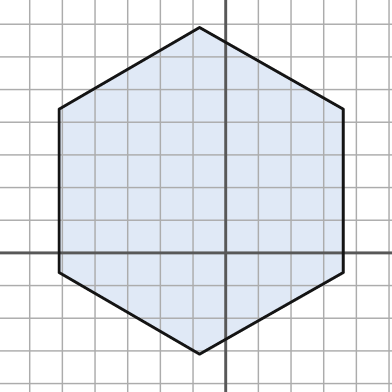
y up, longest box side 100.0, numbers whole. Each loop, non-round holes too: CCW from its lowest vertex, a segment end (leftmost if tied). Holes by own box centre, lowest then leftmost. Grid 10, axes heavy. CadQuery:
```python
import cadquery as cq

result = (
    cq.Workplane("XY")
    .moveTo(-8.0, -31.0)
    .lineTo(36.0, -6.0)
    .lineTo(36.0, 44.0)
    .lineTo(-8.0, 69.0)
    .lineTo(-51.0, 44.0)
    .lineTo(-51.0, -6.0)
    .close()
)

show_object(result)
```